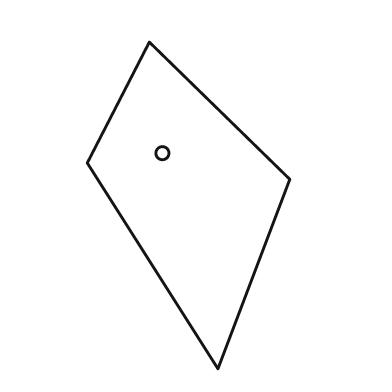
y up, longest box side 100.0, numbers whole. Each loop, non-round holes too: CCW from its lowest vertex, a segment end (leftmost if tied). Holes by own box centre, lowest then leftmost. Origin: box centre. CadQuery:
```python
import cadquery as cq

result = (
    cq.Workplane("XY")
    .moveTo(9.0, -50.0)
    .lineTo(31.0, 8.0)
    .lineTo(-12.0, 50.0)
    .lineTo(-31.0, 13.0)
    .close()
    .moveTo(-8.0, 16.0)
    .circle(2.0)
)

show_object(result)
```